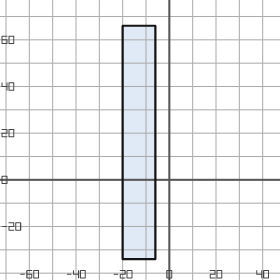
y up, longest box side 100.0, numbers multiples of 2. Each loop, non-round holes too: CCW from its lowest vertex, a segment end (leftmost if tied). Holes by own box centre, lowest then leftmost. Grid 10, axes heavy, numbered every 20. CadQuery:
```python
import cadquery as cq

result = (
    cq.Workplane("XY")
    .moveTo(-20.0, -34.0)
    .lineTo(-6.0, -34.0)
    .lineTo(-6.0, 66.0)
    .lineTo(-20.0, 66.0)
    .close()
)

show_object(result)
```